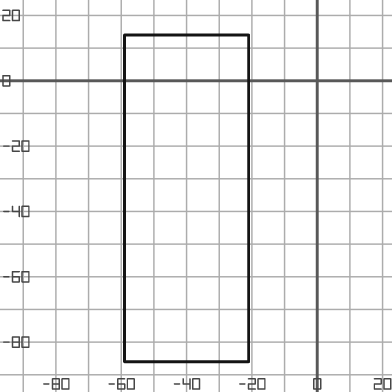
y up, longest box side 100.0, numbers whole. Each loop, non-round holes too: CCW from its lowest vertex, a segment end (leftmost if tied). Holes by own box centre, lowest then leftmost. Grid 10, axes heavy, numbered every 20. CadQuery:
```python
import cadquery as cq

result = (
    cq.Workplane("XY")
    .moveTo(-59.0, -86.0)
    .lineTo(-21.0, -86.0)
    .lineTo(-21.0, 14.0)
    .lineTo(-59.0, 14.0)
    .close()
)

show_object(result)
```